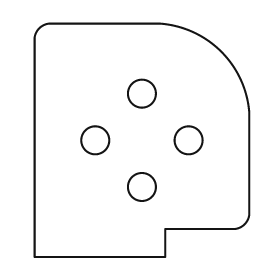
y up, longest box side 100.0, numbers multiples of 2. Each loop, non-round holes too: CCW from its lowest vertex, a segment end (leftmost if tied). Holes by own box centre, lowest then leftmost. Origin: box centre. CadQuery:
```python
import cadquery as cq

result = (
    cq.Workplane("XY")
    .moveTo(-46.0, -50.0)
    .lineTo(10.0, -50.0)
    .lineTo(10.0, -38.0)
    .lineTo(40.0, -38.0)
    .threePointArc((44.0, -36.0), (46.0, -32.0))
    .lineTo(46.0, 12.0)
    .threePointArc((34.0, 38.0), (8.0, 50.0))
    .lineTo(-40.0, 50.0)
    .threePointArc((-44.0, 48.0), (-46.0, 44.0))
    .close()
    .moveTo(0.0, -20.0)
    .circle(6.0)
    .moveTo(-20.0, 0.0)
    .circle(6.0)
    .moveTo(20.0, 0.0)
    .circle(6.0)
    .moveTo(0.0, 20.0)
    .circle(6.0)
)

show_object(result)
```